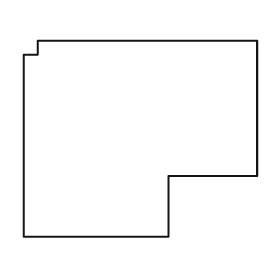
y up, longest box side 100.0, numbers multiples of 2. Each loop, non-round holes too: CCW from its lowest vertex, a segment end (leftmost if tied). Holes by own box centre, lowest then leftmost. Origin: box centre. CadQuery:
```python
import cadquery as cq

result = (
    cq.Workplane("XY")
    .moveTo(-50.0, -42.0)
    .lineTo(12.0, -42.0)
    .lineTo(12.0, -16.0)
    .lineTo(50.0, -16.0)
    .lineTo(50.0, 42.0)
    .lineTo(-44.0, 42.0)
    .lineTo(-44.0, 36.0)
    .lineTo(-50.0, 36.0)
    .close()
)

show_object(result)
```